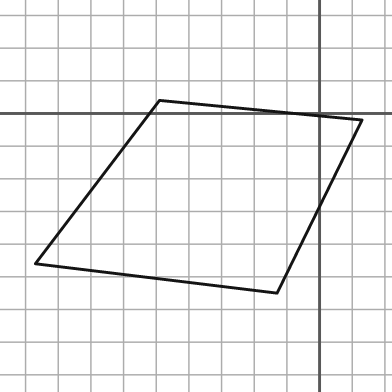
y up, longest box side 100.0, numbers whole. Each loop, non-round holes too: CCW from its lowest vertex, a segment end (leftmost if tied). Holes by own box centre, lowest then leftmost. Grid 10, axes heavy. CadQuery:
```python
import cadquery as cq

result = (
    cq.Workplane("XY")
    .moveTo(-13.0, -55.0)
    .lineTo(13.0, -2.0)
    .lineTo(-49.0, 4.0)
    .lineTo(-87.0, -46.0)
    .close()
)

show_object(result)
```